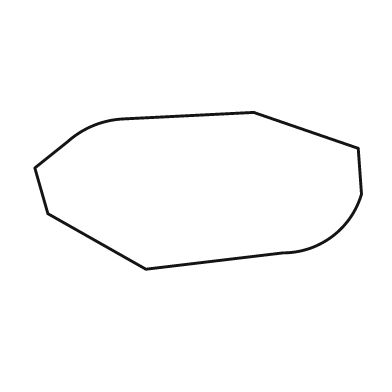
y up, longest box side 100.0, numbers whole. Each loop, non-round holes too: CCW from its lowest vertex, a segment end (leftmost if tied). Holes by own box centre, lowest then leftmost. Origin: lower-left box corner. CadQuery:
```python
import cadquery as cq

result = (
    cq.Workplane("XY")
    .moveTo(34.0, 0.0)
    .lineTo(76.0, 5.0)
    .threePointArc((91.0, 10.0), (100.0, 23.0))
    .lineTo(99.0, 37.0)
    .lineTo(67.0, 48.0)
    .lineTo(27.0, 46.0)
    .threePointArc((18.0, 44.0), (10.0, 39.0))
    .lineTo(0.0, 31.0)
    .lineTo(4.0, 17.0)
    .close()
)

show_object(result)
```